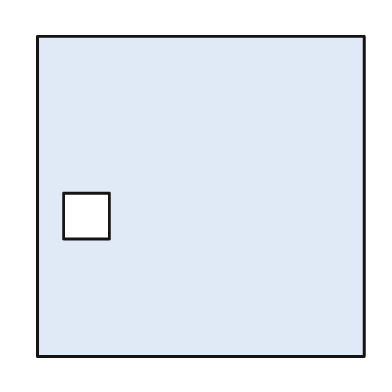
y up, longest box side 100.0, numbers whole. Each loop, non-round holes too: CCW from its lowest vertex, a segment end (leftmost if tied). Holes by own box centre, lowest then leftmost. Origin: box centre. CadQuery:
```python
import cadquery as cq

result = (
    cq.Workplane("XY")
    .moveTo(-50.0, -49.0)
    .lineTo(50.0, -49.0)
    .lineTo(50.0, 49.0)
    .lineTo(-50.0, 49.0)
    .close()
    .moveTo(-42.0, -13.0)
    .lineTo(-28.0, -13.0)
    .lineTo(-28.0, 1.0)
    .lineTo(-42.0, 1.0)
    .close()
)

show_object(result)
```